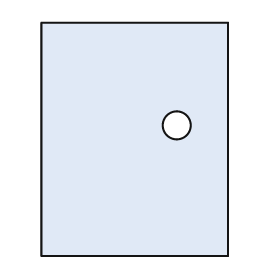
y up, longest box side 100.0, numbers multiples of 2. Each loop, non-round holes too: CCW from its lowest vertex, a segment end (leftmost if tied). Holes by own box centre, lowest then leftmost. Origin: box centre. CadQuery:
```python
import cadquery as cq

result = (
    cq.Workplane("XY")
    .moveTo(-40.0, -50.0)
    .lineTo(40.0, -50.0)
    .lineTo(40.0, 50.0)
    .lineTo(-40.0, 50.0)
    .close()
    .moveTo(18.0, 6.0)
    .circle(6.0)
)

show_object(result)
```